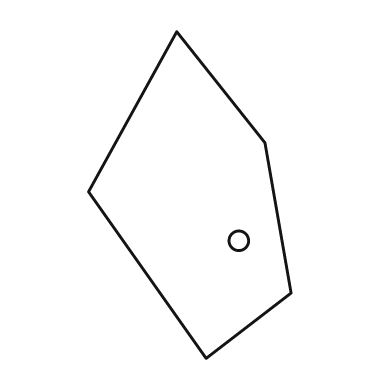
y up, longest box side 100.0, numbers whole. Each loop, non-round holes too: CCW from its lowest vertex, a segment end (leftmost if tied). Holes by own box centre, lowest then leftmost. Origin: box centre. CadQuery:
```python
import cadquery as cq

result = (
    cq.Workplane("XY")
    .moveTo(5.0, -50.0)
    .lineTo(31.0, -30.0)
    .lineTo(23.0, 16.0)
    .lineTo(-4.0, 50.0)
    .lineTo(-31.0, 1.0)
    .close()
    .moveTo(15.0, -14.0)
    .circle(3.0)
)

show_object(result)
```